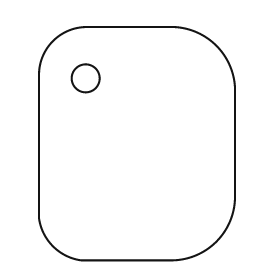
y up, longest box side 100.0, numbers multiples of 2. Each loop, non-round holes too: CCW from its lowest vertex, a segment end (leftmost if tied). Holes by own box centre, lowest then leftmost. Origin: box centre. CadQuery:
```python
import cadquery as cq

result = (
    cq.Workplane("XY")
    .moveTo(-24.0, -50.0)
    .lineTo(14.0, -50.0)
    .threePointArc((34.0, -42.0), (42.0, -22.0))
    .lineTo(42.0, 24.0)
    .threePointArc((34.0, 42.0), (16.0, 50.0))
    .lineTo(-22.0, 50.0)
    .threePointArc((-36.0, 44.0), (-42.0, 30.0))
    .lineTo(-42.0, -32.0)
    .threePointArc((-36.0, -44.0), (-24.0, -50.0))
    .close()
    .moveTo(-22.0, 28.0)
    .circle(6.0)
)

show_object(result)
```